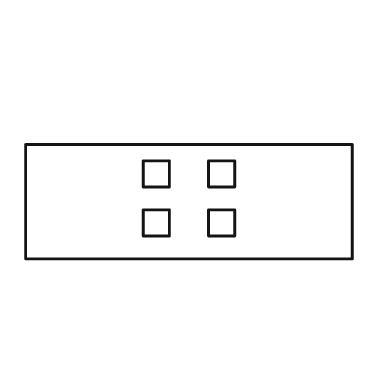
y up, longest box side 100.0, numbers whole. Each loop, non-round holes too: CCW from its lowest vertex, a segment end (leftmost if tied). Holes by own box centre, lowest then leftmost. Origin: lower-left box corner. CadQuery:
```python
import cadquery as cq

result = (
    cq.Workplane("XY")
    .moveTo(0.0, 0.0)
    .lineTo(100.0, 0.0)
    .lineTo(100.0, 35.0)
    .lineTo(0.0, 35.0)
    .close()
    .moveTo(36.0, 7.0)
    .lineTo(44.0, 7.0)
    .lineTo(44.0, 15.0)
    .lineTo(36.0, 15.0)
    .close()
    .moveTo(56.0, 7.0)
    .lineTo(64.0, 7.0)
    .lineTo(64.0, 15.0)
    .lineTo(56.0, 15.0)
    .close()
    .moveTo(36.0, 22.0)
    .lineTo(44.0, 22.0)
    .lineTo(44.0, 30.0)
    .lineTo(36.0, 30.0)
    .close()
    .moveTo(56.0, 22.0)
    .lineTo(64.0, 22.0)
    .lineTo(64.0, 30.0)
    .lineTo(56.0, 30.0)
    .close()
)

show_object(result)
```